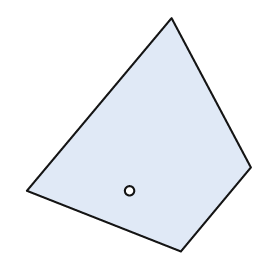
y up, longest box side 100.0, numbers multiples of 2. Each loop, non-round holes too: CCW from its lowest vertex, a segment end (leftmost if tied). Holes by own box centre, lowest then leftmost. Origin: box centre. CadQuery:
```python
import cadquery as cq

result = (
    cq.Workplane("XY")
    .moveTo(18.0, -50.0)
    .lineTo(48.0, -14.0)
    .lineTo(14.0, 50.0)
    .lineTo(-48.0, -24.0)
    .close()
    .moveTo(-4.0, -24.0)
    .circle(2.0)
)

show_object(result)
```